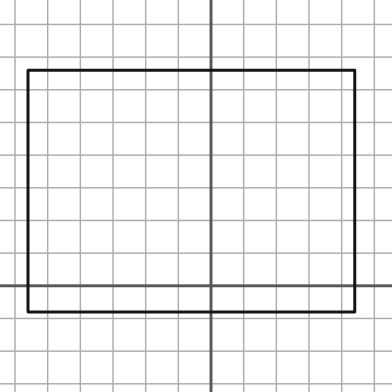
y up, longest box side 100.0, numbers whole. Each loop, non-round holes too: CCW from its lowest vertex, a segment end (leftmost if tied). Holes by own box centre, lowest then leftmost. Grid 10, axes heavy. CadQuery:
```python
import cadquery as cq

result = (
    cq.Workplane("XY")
    .moveTo(-56.0, -8.0)
    .lineTo(44.0, -8.0)
    .lineTo(44.0, 66.0)
    .lineTo(-56.0, 66.0)
    .close()
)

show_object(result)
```